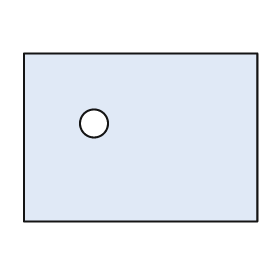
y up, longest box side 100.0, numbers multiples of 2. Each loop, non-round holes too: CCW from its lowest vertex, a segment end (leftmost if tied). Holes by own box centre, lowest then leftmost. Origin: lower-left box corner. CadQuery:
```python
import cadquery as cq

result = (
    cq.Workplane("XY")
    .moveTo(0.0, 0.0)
    .lineTo(100.0, 0.0)
    .lineTo(100.0, 72.0)
    .lineTo(0.0, 72.0)
    .close()
    .moveTo(30.0, 42.0)
    .circle(6.0)
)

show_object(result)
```